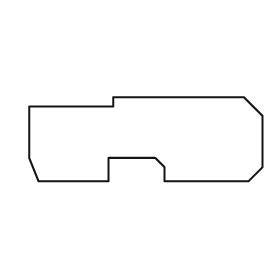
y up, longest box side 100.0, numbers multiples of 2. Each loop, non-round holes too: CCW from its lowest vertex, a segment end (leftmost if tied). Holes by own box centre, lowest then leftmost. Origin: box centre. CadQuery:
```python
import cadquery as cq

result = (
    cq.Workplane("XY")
    .moveTo(-46.0, -18.0)
    .lineTo(-16.0, -18.0)
    .lineTo(-16.0, -8.0)
    .lineTo(4.0, -8.0)
    .lineTo(8.0, -12.0)
    .lineTo(8.0, -18.0)
    .lineTo(44.0, -18.0)
    .lineTo(50.0, -12.0)
    .lineTo(50.0, 10.0)
    .lineTo(42.0, 18.0)
    .lineTo(-14.0, 18.0)
    .lineTo(-14.0, 14.0)
    .lineTo(-50.0, 14.0)
    .lineTo(-50.0, -8.0)
    .close()
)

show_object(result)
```